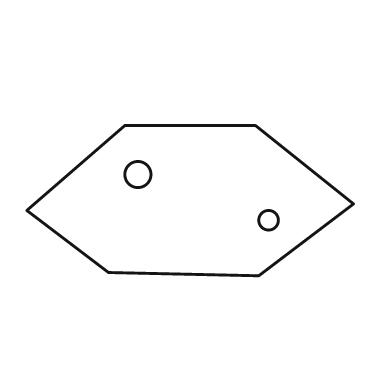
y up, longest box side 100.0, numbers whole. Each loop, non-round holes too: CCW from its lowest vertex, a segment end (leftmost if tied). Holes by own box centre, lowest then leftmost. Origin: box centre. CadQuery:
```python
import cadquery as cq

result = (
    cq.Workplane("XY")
    .moveTo(21.0, -23.0)
    .lineTo(50.0, -1.0)
    .lineTo(20.0, 23.0)
    .lineTo(-20.0, 23.0)
    .lineTo(-50.0, -3.0)
    .lineTo(-25.0, -22.0)
    .close()
    .moveTo(24.0, -6.0)
    .circle(3.0)
    .moveTo(-16.0, 8.0)
    .circle(4.0)
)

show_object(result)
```